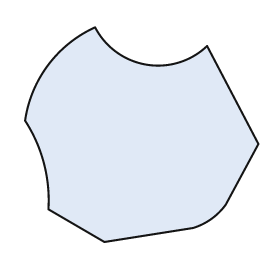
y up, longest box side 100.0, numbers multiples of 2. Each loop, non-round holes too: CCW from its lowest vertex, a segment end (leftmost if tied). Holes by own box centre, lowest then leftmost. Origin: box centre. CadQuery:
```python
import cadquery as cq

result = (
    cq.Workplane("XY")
    .moveTo(-16.0, -46.0)
    .lineTo(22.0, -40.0)
    .threePointArc((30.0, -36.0), (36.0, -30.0))
    .lineTo(50.0, -4.0)
    .lineTo(28.0, 38.0)
    .threePointArc((2.0, 30.0), (-20.0, 46.0))
    .threePointArc((-40.0, 30.0), (-50.0, 6.0))
    .threePointArc((-42.0, -12.0), (-40.0, -32.0))
    .close()
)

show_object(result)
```